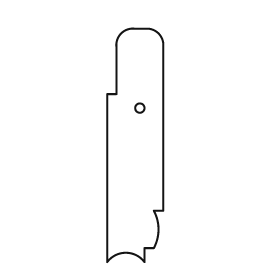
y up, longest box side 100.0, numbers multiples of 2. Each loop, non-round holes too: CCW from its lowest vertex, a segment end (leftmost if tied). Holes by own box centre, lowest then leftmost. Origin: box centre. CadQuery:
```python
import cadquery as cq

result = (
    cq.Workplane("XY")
    .moveTo(-12.0, -50.0)
    .threePointArc((-4.0, -46.0), (4.0, -50.0))
    .lineTo(4.0, -44.0)
    .lineTo(8.0, -44.0)
    .threePointArc((10.0, -36.0), (8.0, -28.0))
    .lineTo(12.0, -28.0)
    .lineTo(12.0, 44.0)
    .threePointArc((10.0, 48.0), (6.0, 50.0))
    .lineTo(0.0, 50.0)
    .threePointArc((-6.0, 48.0), (-8.0, 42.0))
    .lineTo(-8.0, 22.0)
    .lineTo(-12.0, 22.0)
    .close()
    .moveTo(2.0, 16.0)
    .circle(2.0)
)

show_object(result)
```